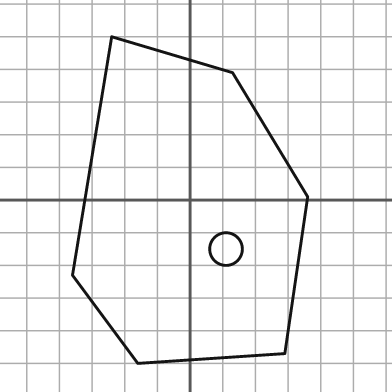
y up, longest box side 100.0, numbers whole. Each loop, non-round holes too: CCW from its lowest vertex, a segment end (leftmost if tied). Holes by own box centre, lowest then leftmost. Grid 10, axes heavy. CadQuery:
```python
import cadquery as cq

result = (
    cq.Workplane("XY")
    .moveTo(-16.0, -50.0)
    .lineTo(29.0, -47.0)
    .lineTo(36.0, 1.0)
    .lineTo(13.0, 39.0)
    .lineTo(-24.0, 50.0)
    .lineTo(-36.0, -23.0)
    .close()
    .moveTo(11.0, -15.0)
    .circle(5.0)
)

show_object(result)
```